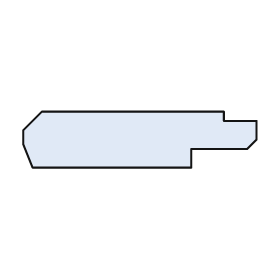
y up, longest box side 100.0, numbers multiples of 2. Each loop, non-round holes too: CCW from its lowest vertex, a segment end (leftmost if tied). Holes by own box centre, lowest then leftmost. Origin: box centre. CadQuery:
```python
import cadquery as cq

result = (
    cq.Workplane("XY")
    .moveTo(-46.0, -12.0)
    .lineTo(22.0, -12.0)
    .lineTo(22.0, -4.0)
    .lineTo(46.0, -4.0)
    .lineTo(50.0, 0.0)
    .lineTo(50.0, 8.0)
    .lineTo(36.0, 8.0)
    .lineTo(36.0, 12.0)
    .lineTo(-42.0, 12.0)
    .lineTo(-50.0, 4.0)
    .lineTo(-50.0, -2.0)
    .close()
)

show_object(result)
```